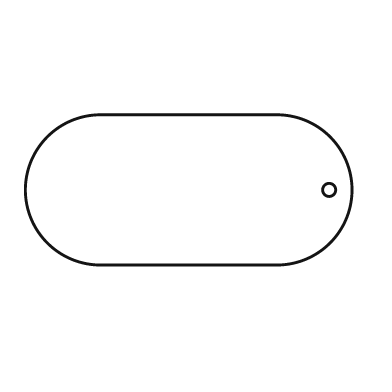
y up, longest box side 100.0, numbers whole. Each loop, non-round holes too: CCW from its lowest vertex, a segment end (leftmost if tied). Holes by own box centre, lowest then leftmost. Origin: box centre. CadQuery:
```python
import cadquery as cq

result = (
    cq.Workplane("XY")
    .moveTo(-27.0, -23.0)
    .lineTo(27.0, -23.0)
    .threePointArc((50.0, 0.0), (27.0, 23.0))
    .lineTo(-27.0, 23.0)
    .threePointArc((-50.0, 0.0), (-27.0, -23.0))
    .close()
    .moveTo(43.0, 0.0)
    .circle(2.0)
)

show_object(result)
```